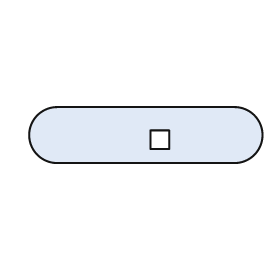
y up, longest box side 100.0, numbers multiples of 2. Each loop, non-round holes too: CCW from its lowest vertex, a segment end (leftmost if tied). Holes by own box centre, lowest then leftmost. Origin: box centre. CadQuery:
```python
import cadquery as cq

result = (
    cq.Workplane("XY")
    .moveTo(-38.0, -12.0)
    .lineTo(38.0, -12.0)
    .threePointArc((50.0, 0.0), (38.0, 12.0))
    .lineTo(-38.0, 12.0)
    .threePointArc((-50.0, 0.0), (-38.0, -12.0))
    .close()
    .moveTo(2.0, -6.0)
    .lineTo(10.0, -6.0)
    .lineTo(10.0, 2.0)
    .lineTo(2.0, 2.0)
    .close()
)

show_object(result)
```